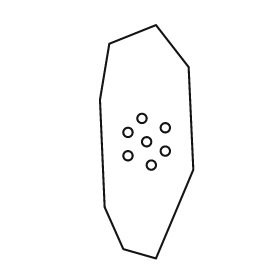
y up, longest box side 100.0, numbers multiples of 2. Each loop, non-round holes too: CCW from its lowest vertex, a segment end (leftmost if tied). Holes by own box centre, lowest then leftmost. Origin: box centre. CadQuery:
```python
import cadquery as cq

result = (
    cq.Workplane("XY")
    .moveTo(4.0, -50.0)
    .lineTo(20.0, -12.0)
    .lineTo(18.0, 32.0)
    .lineTo(4.0, 50.0)
    .lineTo(-16.0, 42.0)
    .lineTo(-20.0, 18.0)
    .lineTo(-18.0, -28.0)
    .lineTo(-10.0, -46.0)
    .close()
    .moveTo(2.0, -10.0)
    .circle(2.0)
    .moveTo(-8.0, -6.0)
    .circle(2.0)
    .moveTo(8.0, -4.0)
    .circle(2.0)
    .moveTo(0.0, 0.0)
    .circle(2.0)
    .moveTo(-8.0, 4.0)
    .circle(2.0)
    .moveTo(8.0, 6.0)
    .circle(2.0)
    .moveTo(-2.0, 10.0)
    .circle(2.0)
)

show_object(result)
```